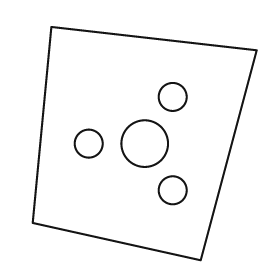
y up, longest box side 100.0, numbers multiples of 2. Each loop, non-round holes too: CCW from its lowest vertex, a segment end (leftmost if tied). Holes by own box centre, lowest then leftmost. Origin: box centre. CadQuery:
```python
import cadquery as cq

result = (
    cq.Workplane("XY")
    .moveTo(24.0, -50.0)
    .lineTo(48.0, 40.0)
    .lineTo(-40.0, 50.0)
    .lineTo(-48.0, -34.0)
    .close()
    .moveTo(12.0, -20.0)
    .circle(6.0)
    .moveTo(-24.0, 0.0)
    .circle(6.0)
    .moveTo(0.0, 0.0)
    .circle(10.0)
    .moveTo(12.0, 20.0)
    .circle(6.0)
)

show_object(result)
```